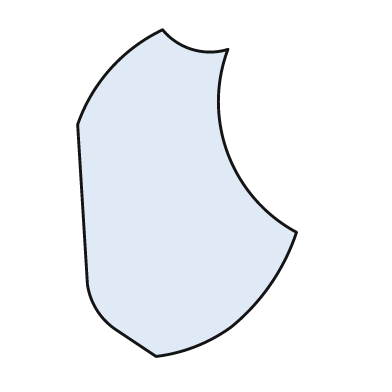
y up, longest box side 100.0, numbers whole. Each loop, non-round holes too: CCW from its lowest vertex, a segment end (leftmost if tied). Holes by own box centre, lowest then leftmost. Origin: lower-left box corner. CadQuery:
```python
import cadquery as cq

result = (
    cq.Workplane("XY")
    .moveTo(24.0, 0.0)
    .threePointArc((36.0, 3.0), (47.0, 9.0))
    .threePointArc((59.0, 22.0), (67.0, 38.0))
    .threePointArc((46.0, 62.0), (46.0, 94.0))
    .threePointArc((35.0, 94.0), (26.0, 100.0))
    .threePointArc((10.0, 88.0), (0.0, 71.0))
    .lineTo(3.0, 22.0)
    .threePointArc((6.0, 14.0), (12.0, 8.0))
    .close()
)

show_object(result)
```